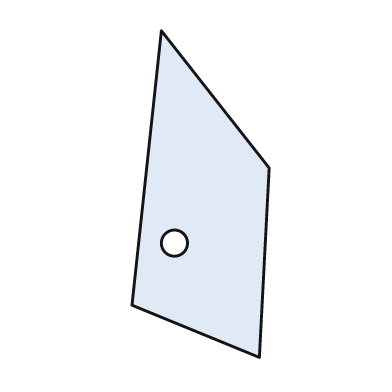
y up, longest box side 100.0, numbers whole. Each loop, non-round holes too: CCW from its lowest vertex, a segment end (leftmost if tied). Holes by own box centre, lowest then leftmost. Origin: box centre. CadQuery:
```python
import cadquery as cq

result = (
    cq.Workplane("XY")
    .moveTo(18.0, -50.0)
    .lineTo(21.0, 8.0)
    .lineTo(-12.0, 50.0)
    .lineTo(-21.0, -34.0)
    .close()
    .moveTo(-8.0, -15.0)
    .circle(4.0)
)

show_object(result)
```